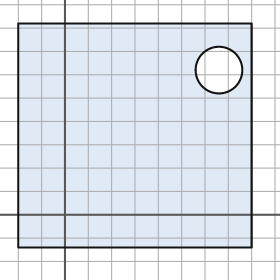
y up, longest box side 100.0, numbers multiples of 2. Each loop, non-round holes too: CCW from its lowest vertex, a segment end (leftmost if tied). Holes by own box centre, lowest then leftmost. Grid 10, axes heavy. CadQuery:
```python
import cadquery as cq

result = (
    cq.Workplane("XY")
    .moveTo(-20.0, -14.0)
    .lineTo(80.0, -14.0)
    .lineTo(80.0, 82.0)
    .lineTo(-20.0, 82.0)
    .close()
    .moveTo(66.0, 62.0)
    .circle(10.0)
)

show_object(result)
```